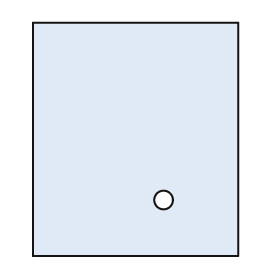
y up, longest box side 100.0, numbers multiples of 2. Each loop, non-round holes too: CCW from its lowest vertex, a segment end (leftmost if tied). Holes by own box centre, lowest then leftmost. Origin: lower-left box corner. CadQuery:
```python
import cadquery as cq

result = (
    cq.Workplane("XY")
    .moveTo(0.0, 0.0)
    .lineTo(88.0, 0.0)
    .lineTo(88.0, 100.0)
    .lineTo(0.0, 100.0)
    .close()
    .moveTo(56.0, 24.0)
    .circle(4.0)
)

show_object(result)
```